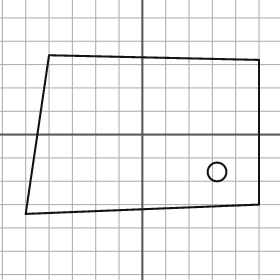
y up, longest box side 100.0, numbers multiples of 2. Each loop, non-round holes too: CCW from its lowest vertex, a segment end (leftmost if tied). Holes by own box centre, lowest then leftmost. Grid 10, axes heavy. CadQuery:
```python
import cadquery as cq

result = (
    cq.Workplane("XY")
    .moveTo(-50.0, -34.0)
    .lineTo(50.0, -30.0)
    .lineTo(50.0, 32.0)
    .lineTo(-40.0, 34.0)
    .close()
    .moveTo(32.0, -16.0)
    .circle(4.0)
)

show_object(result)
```